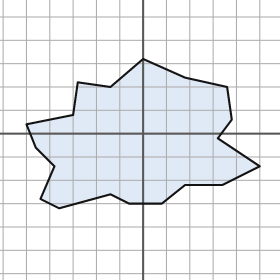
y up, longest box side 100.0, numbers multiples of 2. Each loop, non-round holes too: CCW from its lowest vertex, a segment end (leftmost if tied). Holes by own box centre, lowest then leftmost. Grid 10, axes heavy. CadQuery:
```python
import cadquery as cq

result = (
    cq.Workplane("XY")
    .moveTo(-36.0, -32.0)
    .lineTo(-14.0, -26.0)
    .lineTo(-6.0, -30.0)
    .lineTo(8.0, -30.0)
    .lineTo(18.0, -22.0)
    .lineTo(34.0, -22.0)
    .lineTo(50.0, -14.0)
    .lineTo(32.0, -2.0)
    .lineTo(38.0, 6.0)
    .lineTo(36.0, 20.0)
    .lineTo(18.0, 24.0)
    .lineTo(0.0, 32.0)
    .lineTo(-14.0, 20.0)
    .lineTo(-28.0, 22.0)
    .lineTo(-30.0, 8.0)
    .lineTo(-50.0, 4.0)
    .lineTo(-46.0, -6.0)
    .lineTo(-38.0, -14.0)
    .lineTo(-44.0, -28.0)
    .close()
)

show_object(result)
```